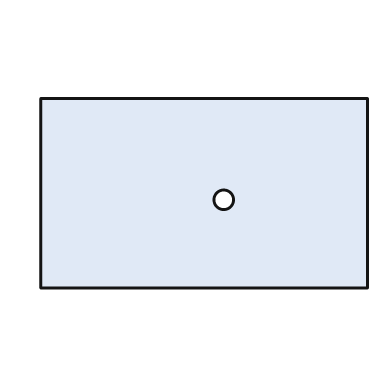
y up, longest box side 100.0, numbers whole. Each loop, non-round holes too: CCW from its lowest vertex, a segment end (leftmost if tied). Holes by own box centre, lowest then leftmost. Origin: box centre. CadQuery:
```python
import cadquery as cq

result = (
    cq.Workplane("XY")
    .moveTo(-50.0, -29.0)
    .lineTo(50.0, -29.0)
    .lineTo(50.0, 29.0)
    .lineTo(-50.0, 29.0)
    .close()
    .moveTo(6.0, -2.0)
    .circle(3.0)
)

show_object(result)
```